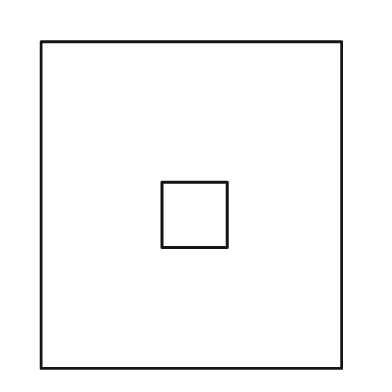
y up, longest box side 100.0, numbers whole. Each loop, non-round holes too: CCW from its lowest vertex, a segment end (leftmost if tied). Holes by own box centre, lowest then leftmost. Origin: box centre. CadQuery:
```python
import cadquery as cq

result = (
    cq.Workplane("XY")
    .moveTo(-46.0, -50.0)
    .lineTo(46.0, -50.0)
    .lineTo(46.0, 50.0)
    .lineTo(-46.0, 50.0)
    .close()
    .moveTo(-9.0, -13.0)
    .lineTo(11.0, -13.0)
    .lineTo(11.0, 7.0)
    .lineTo(-9.0, 7.0)
    .close()
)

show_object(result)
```